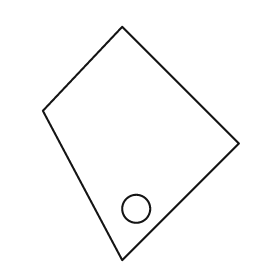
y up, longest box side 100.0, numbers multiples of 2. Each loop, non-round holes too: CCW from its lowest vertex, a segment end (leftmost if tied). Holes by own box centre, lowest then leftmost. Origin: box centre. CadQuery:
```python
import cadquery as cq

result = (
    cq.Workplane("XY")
    .moveTo(-8.0, -50.0)
    .lineTo(42.0, 0.0)
    .lineTo(-8.0, 50.0)
    .lineTo(-42.0, 14.0)
    .close()
    .moveTo(-2.0, -28.0)
    .circle(6.0)
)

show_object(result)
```